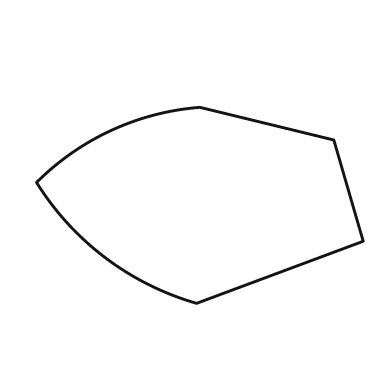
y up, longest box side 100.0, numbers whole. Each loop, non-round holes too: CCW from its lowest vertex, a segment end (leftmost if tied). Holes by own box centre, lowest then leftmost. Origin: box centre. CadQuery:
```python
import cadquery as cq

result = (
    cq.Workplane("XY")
    .moveTo(-1.0, -30.0)
    .lineTo(50.0, -11.0)
    .lineTo(41.0, 20.0)
    .lineTo(0.0, 30.0)
    .threePointArc((-27.0, 23.0), (-50.0, 7.0))
    .threePointArc((-29.0, -16.0), (-1.0, -30.0))
    .close()
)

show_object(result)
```